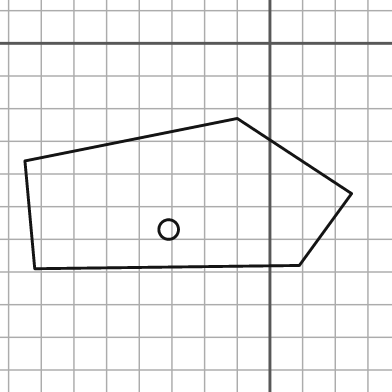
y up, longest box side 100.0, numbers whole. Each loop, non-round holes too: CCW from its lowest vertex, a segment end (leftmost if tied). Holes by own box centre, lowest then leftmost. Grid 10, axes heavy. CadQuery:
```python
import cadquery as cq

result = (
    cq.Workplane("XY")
    .moveTo(-72.0, -69.0)
    .lineTo(9.0, -68.0)
    .lineTo(25.0, -46.0)
    .lineTo(-10.0, -23.0)
    .lineTo(-75.0, -36.0)
    .close()
    .moveTo(-31.0, -57.0)
    .circle(3.0)
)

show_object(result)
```